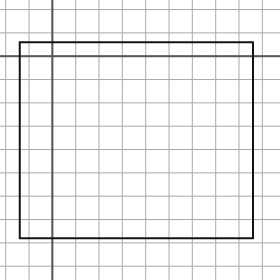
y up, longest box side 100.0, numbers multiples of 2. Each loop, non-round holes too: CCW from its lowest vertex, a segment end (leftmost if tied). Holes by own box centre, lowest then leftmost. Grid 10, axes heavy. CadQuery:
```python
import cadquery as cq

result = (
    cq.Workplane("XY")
    .moveTo(-14.0, -78.0)
    .lineTo(86.0, -78.0)
    .lineTo(86.0, 6.0)
    .lineTo(-14.0, 6.0)
    .close()
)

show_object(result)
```